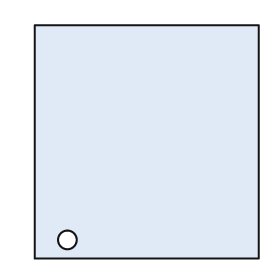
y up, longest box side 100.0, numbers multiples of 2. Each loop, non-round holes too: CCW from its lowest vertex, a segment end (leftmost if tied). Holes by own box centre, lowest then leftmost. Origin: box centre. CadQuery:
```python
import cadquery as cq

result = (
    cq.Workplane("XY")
    .moveTo(-48.0, -50.0)
    .lineTo(48.0, -50.0)
    .lineTo(48.0, 50.0)
    .lineTo(-48.0, 50.0)
    .close()
    .moveTo(-34.0, -42.0)
    .circle(4.0)
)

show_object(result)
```